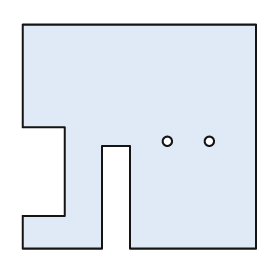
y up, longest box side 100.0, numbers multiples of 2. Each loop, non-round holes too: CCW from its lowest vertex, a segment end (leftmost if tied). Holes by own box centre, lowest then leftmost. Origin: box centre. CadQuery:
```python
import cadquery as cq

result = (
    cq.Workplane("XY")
    .moveTo(-50.0, -48.0)
    .lineTo(-16.0, -48.0)
    .lineTo(-16.0, -4.0)
    .lineTo(-4.0, -4.0)
    .lineTo(-4.0, -48.0)
    .lineTo(50.0, -48.0)
    .lineTo(50.0, 48.0)
    .lineTo(-50.0, 48.0)
    .lineTo(-50.0, 4.0)
    .lineTo(-32.0, 4.0)
    .lineTo(-32.0, -34.0)
    .lineTo(-50.0, -34.0)
    .close()
    .moveTo(12.0, -2.0)
    .circle(2.0)
    .moveTo(30.0, -2.0)
    .circle(2.0)
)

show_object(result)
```